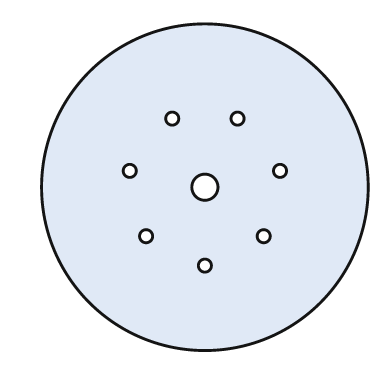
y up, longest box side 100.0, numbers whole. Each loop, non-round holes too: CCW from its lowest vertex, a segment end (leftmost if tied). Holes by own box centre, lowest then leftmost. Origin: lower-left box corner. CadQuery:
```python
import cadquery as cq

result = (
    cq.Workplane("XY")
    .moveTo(50.0, 50.0)
    .circle(50.0)
    .moveTo(50.0, 26.0)
    .circle(2.0)
    .moveTo(32.0, 35.0)
    .circle(2.0)
    .moveTo(68.0, 35.0)
    .circle(2.0)
    .moveTo(50.0, 50.0)
    .circle(4.0)
    .moveTo(27.0, 55.0)
    .circle(2.0)
    .moveTo(73.0, 55.0)
    .circle(2.0)
    .moveTo(40.0, 71.0)
    .circle(2.0)
    .moveTo(60.0, 71.0)
    .circle(2.0)
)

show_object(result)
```